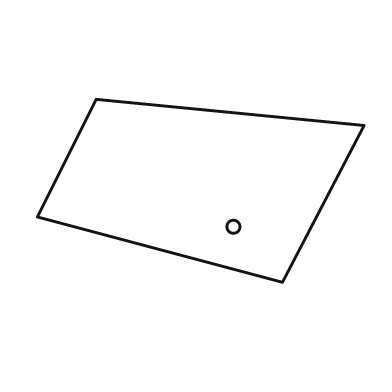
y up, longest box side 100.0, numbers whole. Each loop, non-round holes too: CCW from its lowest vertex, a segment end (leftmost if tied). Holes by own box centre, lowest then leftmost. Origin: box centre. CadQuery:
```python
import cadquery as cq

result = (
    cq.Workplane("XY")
    .moveTo(25.0, -28.0)
    .lineTo(50.0, 20.0)
    .lineTo(-32.0, 28.0)
    .lineTo(-50.0, -8.0)
    .close()
    .moveTo(10.0, -11.0)
    .circle(2.0)
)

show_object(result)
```